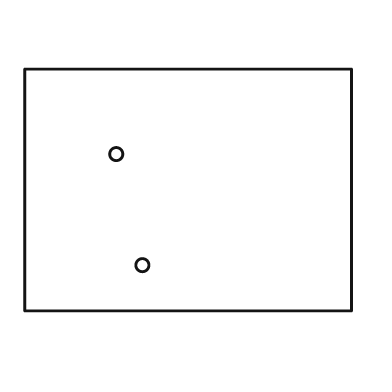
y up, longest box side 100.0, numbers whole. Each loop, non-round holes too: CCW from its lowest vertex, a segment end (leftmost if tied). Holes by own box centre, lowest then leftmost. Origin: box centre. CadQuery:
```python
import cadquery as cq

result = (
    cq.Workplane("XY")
    .moveTo(-50.0, -37.0)
    .lineTo(50.0, -37.0)
    .lineTo(50.0, 37.0)
    .lineTo(-50.0, 37.0)
    .close()
    .moveTo(-14.0, -23.0)
    .circle(2.0)
    .moveTo(-22.0, 11.0)
    .circle(2.0)
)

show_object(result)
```